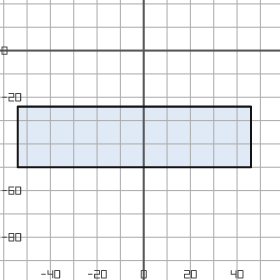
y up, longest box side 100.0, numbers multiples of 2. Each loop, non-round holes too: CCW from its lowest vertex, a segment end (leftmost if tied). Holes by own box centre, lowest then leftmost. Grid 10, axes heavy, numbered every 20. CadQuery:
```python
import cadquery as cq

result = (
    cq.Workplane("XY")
    .moveTo(-54.0, -50.0)
    .lineTo(46.0, -50.0)
    .lineTo(46.0, -24.0)
    .lineTo(-54.0, -24.0)
    .close()
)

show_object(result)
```